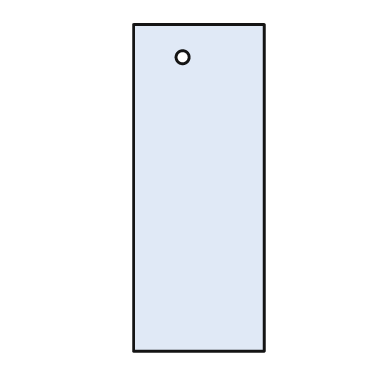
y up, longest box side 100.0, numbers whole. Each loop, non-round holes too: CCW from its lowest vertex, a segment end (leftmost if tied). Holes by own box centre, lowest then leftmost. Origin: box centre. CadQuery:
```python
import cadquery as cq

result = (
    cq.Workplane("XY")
    .moveTo(-20.0, -50.0)
    .lineTo(20.0, -50.0)
    .lineTo(20.0, 50.0)
    .lineTo(-20.0, 50.0)
    .close()
    .moveTo(-5.0, 40.0)
    .circle(2.0)
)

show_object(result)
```